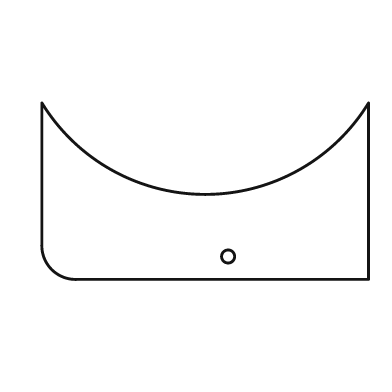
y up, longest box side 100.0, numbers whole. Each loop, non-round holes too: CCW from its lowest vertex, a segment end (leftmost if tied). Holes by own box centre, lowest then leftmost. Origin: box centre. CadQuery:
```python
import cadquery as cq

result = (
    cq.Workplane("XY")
    .moveTo(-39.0, -27.0)
    .lineTo(50.0, -27.0)
    .lineTo(50.0, 27.0)
    .threePointArc((0.0, -1.0), (-50.0, 27.0))
    .lineTo(-50.0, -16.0)
    .threePointArc((-47.0, -24.0), (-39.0, -27.0))
    .close()
    .moveTo(7.0, -20.0)
    .circle(2.0)
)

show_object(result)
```